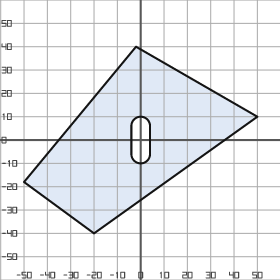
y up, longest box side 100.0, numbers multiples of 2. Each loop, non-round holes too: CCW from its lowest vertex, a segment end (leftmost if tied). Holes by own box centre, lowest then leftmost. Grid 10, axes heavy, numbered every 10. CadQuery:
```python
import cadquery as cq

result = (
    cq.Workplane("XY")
    .moveTo(-20.0, -40.0)
    .lineTo(50.0, 10.0)
    .lineTo(-2.0, 40.0)
    .lineTo(-50.0, -18.0)
    .close()
    .moveTo(-4.0, -6.0)
    .threePointArc((0.0, -10.0), (4.0, -6.0))
    .lineTo(4.0, 6.0)
    .threePointArc((0.0, 10.0), (-4.0, 6.0))
    .close()
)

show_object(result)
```